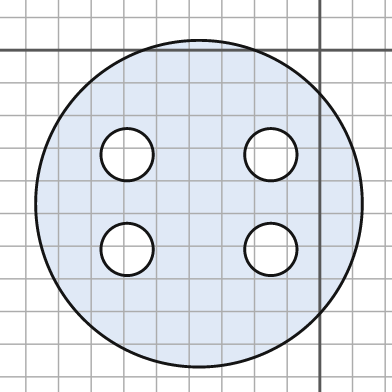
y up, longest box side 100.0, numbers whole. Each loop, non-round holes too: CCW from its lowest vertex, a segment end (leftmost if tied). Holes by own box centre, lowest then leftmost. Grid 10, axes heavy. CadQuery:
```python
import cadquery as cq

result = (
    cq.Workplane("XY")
    .moveTo(-37.0, -47.0)
    .circle(50.0)
    .moveTo(-59.0, -61.0)
    .circle(8.0)
    .moveTo(-15.0, -61.0)
    .circle(8.0)
    .moveTo(-59.0, -32.0)
    .circle(8.0)
    .moveTo(-15.0, -32.0)
    .circle(8.0)
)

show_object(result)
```